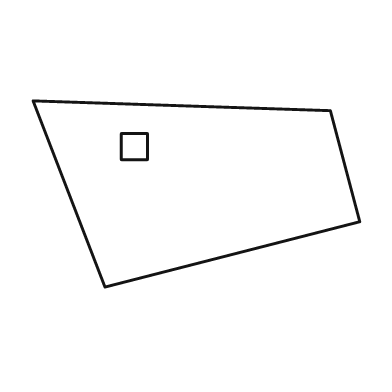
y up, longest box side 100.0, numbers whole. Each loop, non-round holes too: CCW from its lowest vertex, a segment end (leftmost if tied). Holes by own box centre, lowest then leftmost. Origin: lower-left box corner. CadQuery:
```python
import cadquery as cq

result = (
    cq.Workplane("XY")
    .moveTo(22.0, 0.0)
    .lineTo(100.0, 20.0)
    .lineTo(91.0, 54.0)
    .lineTo(0.0, 57.0)
    .close()
    .moveTo(27.0, 39.0)
    .lineTo(35.0, 39.0)
    .lineTo(35.0, 47.0)
    .lineTo(27.0, 47.0)
    .close()
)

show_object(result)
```